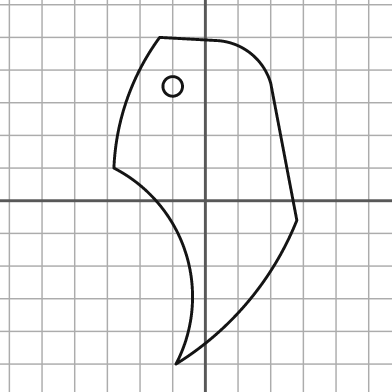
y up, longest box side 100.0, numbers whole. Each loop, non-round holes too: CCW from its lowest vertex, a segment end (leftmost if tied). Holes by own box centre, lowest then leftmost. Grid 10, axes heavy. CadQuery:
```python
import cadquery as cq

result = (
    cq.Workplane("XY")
    .moveTo(-9.0, -50.0)
    .threePointArc((13.0, -31.0), (28.0, -6.0))
    .lineTo(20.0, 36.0)
    .threePointArc((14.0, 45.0), (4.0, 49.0))
    .lineTo(-14.0, 50.0)
    .threePointArc((-24.0, 31.0), (-28.0, 10.0))
    .threePointArc((-6.0, -16.0), (-9.0, -50.0))
    .close()
    .moveTo(-10.0, 35.0)
    .circle(3.0)
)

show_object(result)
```